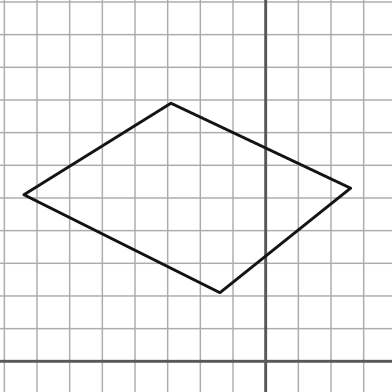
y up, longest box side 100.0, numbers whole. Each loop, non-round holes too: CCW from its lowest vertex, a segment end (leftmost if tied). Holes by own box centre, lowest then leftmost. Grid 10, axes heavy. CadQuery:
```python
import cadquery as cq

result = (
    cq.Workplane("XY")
    .moveTo(-14.0, 21.0)
    .lineTo(26.0, 53.0)
    .lineTo(-29.0, 79.0)
    .lineTo(-74.0, 51.0)
    .close()
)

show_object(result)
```